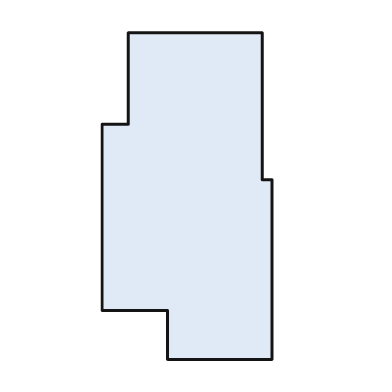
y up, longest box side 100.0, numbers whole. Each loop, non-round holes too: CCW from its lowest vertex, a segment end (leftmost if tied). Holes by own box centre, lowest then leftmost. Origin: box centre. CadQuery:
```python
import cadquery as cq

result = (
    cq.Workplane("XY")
    .moveTo(-6.0, -50.0)
    .lineTo(26.0, -50.0)
    .lineTo(26.0, 5.0)
    .lineTo(23.0, 5.0)
    .lineTo(23.0, 50.0)
    .lineTo(-18.0, 50.0)
    .lineTo(-18.0, 22.0)
    .lineTo(-26.0, 22.0)
    .lineTo(-26.0, -35.0)
    .lineTo(-6.0, -35.0)
    .close()
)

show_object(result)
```